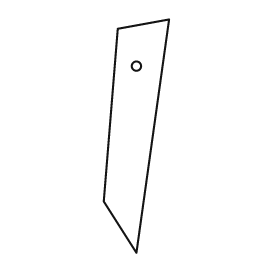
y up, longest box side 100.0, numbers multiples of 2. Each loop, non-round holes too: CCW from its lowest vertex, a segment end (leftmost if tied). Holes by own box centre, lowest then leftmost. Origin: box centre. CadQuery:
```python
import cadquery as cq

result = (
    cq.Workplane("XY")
    .moveTo(0.0, -50.0)
    .lineTo(14.0, 50.0)
    .lineTo(-8.0, 46.0)
    .lineTo(-14.0, -28.0)
    .close()
    .moveTo(0.0, 30.0)
    .circle(2.0)
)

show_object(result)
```